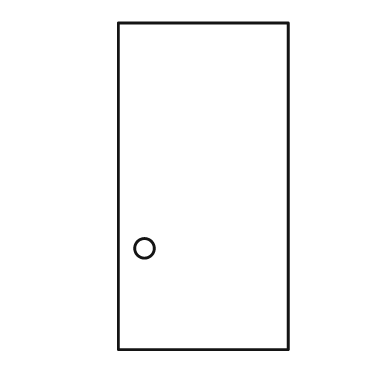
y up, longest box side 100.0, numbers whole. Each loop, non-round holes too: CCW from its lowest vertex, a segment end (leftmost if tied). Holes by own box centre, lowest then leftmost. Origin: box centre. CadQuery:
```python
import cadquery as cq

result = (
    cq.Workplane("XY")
    .moveTo(-26.0, -50.0)
    .lineTo(26.0, -50.0)
    .lineTo(26.0, 50.0)
    .lineTo(-26.0, 50.0)
    .close()
    .moveTo(-18.0, -19.0)
    .circle(3.0)
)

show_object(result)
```